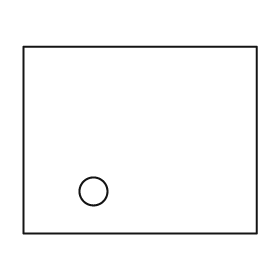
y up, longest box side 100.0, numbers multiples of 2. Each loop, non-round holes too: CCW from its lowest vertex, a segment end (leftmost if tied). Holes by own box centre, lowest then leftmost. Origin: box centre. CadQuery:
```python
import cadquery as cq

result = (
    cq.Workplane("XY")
    .moveTo(-50.0, -40.0)
    .lineTo(50.0, -40.0)
    .lineTo(50.0, 40.0)
    .lineTo(-50.0, 40.0)
    .close()
    .moveTo(-20.0, -22.0)
    .circle(6.0)
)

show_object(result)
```